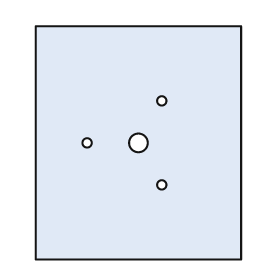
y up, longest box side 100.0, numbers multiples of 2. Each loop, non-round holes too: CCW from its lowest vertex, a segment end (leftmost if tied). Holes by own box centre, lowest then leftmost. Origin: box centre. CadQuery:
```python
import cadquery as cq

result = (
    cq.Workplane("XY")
    .moveTo(-44.0, -50.0)
    .lineTo(44.0, -50.0)
    .lineTo(44.0, 50.0)
    .lineTo(-44.0, 50.0)
    .close()
    .moveTo(10.0, -18.0)
    .circle(2.0)
    .moveTo(-22.0, 0.0)
    .circle(2.0)
    .moveTo(0.0, 0.0)
    .circle(4.0)
    .moveTo(10.0, 18.0)
    .circle(2.0)
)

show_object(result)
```